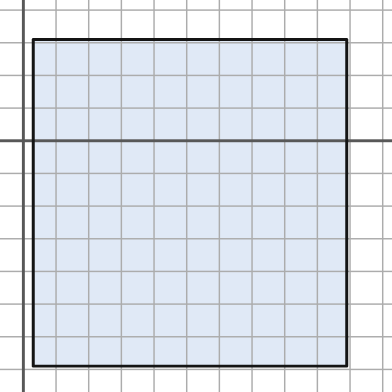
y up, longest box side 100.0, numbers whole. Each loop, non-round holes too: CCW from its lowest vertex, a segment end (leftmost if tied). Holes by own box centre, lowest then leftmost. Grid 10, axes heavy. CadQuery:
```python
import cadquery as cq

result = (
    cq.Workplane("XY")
    .moveTo(3.0, -69.0)
    .lineTo(99.0, -69.0)
    .lineTo(99.0, 31.0)
    .lineTo(3.0, 31.0)
    .close()
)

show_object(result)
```